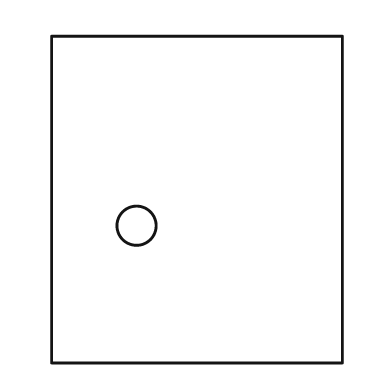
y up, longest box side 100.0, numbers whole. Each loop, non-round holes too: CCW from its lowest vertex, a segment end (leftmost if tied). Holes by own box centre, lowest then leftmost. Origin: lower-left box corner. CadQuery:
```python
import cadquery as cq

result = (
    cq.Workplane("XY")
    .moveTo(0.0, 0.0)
    .lineTo(89.0, 0.0)
    .lineTo(89.0, 100.0)
    .lineTo(0.0, 100.0)
    .close()
    .moveTo(26.0, 42.0)
    .circle(6.0)
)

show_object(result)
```